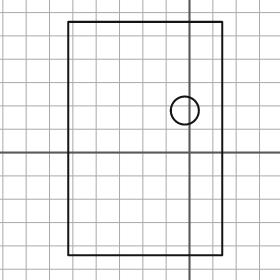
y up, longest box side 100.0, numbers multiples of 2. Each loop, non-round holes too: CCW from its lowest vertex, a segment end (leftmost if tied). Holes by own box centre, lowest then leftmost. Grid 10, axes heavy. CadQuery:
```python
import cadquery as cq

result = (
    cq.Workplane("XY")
    .moveTo(-52.0, -44.0)
    .lineTo(14.0, -44.0)
    .lineTo(14.0, 56.0)
    .lineTo(-52.0, 56.0)
    .close()
    .moveTo(-2.0, 18.0)
    .circle(6.0)
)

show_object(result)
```